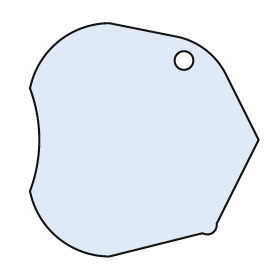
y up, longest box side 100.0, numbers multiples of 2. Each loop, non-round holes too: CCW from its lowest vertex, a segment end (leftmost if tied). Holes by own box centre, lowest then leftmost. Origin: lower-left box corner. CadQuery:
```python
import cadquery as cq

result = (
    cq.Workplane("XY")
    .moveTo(34.0, 0.0)
    .lineTo(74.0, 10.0)
    .threePointArc((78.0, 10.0), (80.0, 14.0))
    .lineTo(98.0, 50.0)
    .lineTo(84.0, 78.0)
    .threePointArc((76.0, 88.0), (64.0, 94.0))
    .lineTo(34.0, 100.0)
    .threePointArc((12.0, 92.0), (0.0, 72.0))
    .threePointArc((4.0, 50.0), (0.0, 28.0))
    .threePointArc((12.0, 8.0), (34.0, 0.0))
    .close()
    .moveTo(66.0, 84.0)
    .circle(4.0)
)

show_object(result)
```